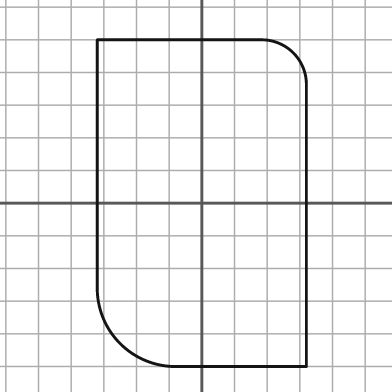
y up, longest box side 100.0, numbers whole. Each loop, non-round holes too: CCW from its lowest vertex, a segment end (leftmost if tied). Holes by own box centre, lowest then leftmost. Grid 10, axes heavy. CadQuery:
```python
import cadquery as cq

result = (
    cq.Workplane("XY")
    .moveTo(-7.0, -50.0)
    .lineTo(32.0, -50.0)
    .lineTo(32.0, 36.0)
    .threePointArc((28.0, 46.0), (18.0, 50.0))
    .lineTo(-32.0, 50.0)
    .lineTo(-32.0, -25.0)
    .threePointArc((-25.0, -43.0), (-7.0, -50.0))
    .close()
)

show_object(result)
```